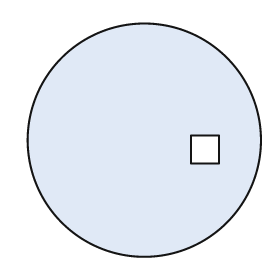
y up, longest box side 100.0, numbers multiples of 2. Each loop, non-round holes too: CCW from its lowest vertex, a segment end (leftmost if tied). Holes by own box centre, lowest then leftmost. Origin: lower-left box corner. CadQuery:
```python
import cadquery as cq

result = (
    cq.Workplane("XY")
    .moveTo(50.0, 50.0)
    .circle(50.0)
    .moveTo(70.0, 40.0)
    .lineTo(82.0, 40.0)
    .lineTo(82.0, 52.0)
    .lineTo(70.0, 52.0)
    .close()
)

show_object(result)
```